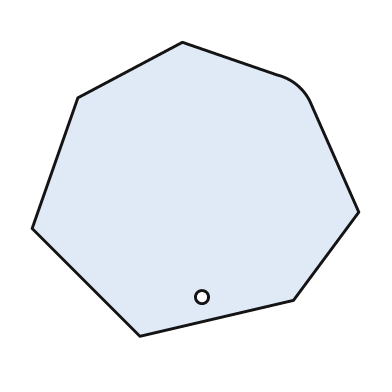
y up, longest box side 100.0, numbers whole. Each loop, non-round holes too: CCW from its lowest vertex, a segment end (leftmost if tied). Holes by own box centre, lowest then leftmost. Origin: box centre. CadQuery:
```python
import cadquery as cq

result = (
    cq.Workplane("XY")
    .moveTo(-17.0, -45.0)
    .lineTo(30.0, -34.0)
    .lineTo(50.0, -7.0)
    .lineTo(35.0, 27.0)
    .threePointArc((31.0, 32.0), (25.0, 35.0))
    .lineTo(-4.0, 45.0)
    .lineTo(-36.0, 28.0)
    .lineTo(-50.0, -12.0)
    .close()
    .moveTo(2.0, -33.0)
    .circle(2.0)
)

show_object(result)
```